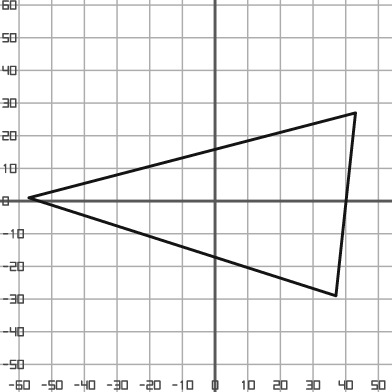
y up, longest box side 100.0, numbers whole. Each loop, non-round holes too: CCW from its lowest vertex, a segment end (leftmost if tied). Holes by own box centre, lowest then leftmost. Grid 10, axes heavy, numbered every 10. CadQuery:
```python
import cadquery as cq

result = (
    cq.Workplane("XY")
    .moveTo(37.0, -29.0)
    .lineTo(43.0, 27.0)
    .lineTo(-57.0, 1.0)
    .close()
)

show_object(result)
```